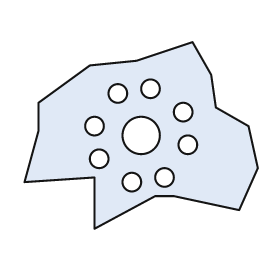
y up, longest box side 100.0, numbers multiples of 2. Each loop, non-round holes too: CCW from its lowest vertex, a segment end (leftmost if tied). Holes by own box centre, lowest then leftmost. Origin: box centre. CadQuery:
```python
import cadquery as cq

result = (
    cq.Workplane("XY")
    .moveTo(-20.0, -40.0)
    .lineTo(6.0, -26.0)
    .lineTo(14.0, -26.0)
    .lineTo(42.0, -32.0)
    .lineTo(50.0, -14.0)
    .lineTo(46.0, 4.0)
    .lineTo(32.0, 12.0)
    .lineTo(30.0, 26.0)
    .lineTo(22.0, 40.0)
    .lineTo(-2.0, 32.0)
    .lineTo(-22.0, 30.0)
    .lineTo(-44.0, 14.0)
    .lineTo(-44.0, 2.0)
    .lineTo(-50.0, -20.0)
    .lineTo(-20.0, -18.0)
    .close()
    .moveTo(-4.0, -20.0)
    .circle(4.0)
    .moveTo(10.0, -18.0)
    .circle(4.0)
    .moveTo(-18.0, -10.0)
    .circle(4.0)
    .moveTo(20.0, -4.0)
    .circle(4.0)
    .moveTo(0.0, 0.0)
    .circle(8.0)
    .moveTo(-20.0, 4.0)
    .circle(4.0)
    .moveTo(18.0, 10.0)
    .circle(4.0)
    .moveTo(-10.0, 18.0)
    .circle(4.0)
    .moveTo(4.0, 20.0)
    .circle(4.0)
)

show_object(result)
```